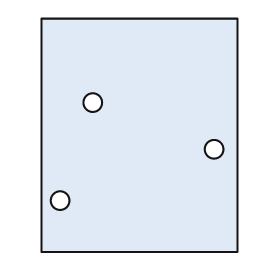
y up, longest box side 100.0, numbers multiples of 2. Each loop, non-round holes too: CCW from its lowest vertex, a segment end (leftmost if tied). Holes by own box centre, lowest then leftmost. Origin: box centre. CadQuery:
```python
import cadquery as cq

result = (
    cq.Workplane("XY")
    .moveTo(-42.0, -50.0)
    .lineTo(42.0, -50.0)
    .lineTo(42.0, 50.0)
    .lineTo(-42.0, 50.0)
    .close()
    .moveTo(-34.0, -28.0)
    .circle(4.0)
    .moveTo(32.0, -6.0)
    .circle(4.0)
    .moveTo(-20.0, 14.0)
    .circle(4.0)
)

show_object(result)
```